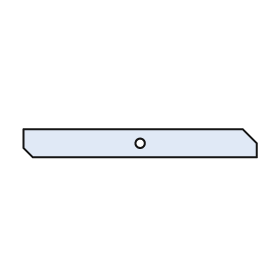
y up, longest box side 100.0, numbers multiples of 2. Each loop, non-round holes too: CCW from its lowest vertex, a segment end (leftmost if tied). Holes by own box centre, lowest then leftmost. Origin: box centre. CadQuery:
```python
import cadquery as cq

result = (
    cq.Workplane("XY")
    .moveTo(-46.0, -6.0)
    .lineTo(50.0, -6.0)
    .lineTo(50.0, 0.0)
    .lineTo(44.0, 6.0)
    .lineTo(-50.0, 6.0)
    .lineTo(-50.0, -2.0)
    .close()
    .moveTo(0.0, 0.0)
    .circle(2.0)
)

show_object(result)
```